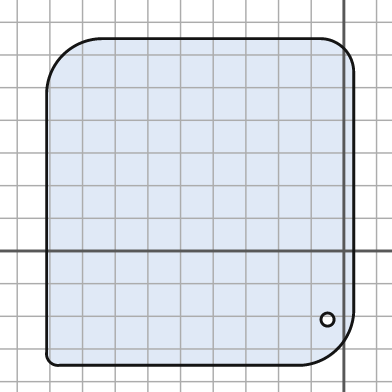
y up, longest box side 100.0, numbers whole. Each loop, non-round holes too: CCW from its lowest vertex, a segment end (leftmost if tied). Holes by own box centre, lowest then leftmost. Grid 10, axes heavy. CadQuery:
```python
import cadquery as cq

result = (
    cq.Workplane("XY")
    .moveTo(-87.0, -35.0)
    .lineTo(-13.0, -35.0)
    .threePointArc((-2.0, -30.0), (3.0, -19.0))
    .lineTo(3.0, 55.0)
    .threePointArc((0.0, 62.0), (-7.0, 65.0))
    .lineTo(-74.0, 65.0)
    .threePointArc((-86.0, 60.0), (-91.0, 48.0))
    .lineTo(-91.0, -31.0)
    .threePointArc((-90.0, -34.0), (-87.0, -35.0))
    .close()
    .moveTo(-5.0, -21.0)
    .circle(2.0)
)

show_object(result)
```